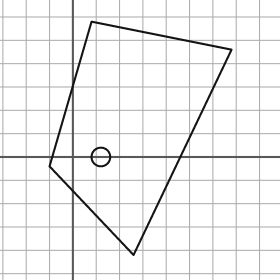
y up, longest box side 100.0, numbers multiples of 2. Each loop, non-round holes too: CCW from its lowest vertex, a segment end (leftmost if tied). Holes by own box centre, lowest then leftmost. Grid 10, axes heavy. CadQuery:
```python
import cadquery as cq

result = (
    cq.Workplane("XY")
    .moveTo(26.0, -42.0)
    .lineTo(68.0, 46.0)
    .lineTo(8.0, 58.0)
    .lineTo(-10.0, -4.0)
    .close()
    .moveTo(12.0, 0.0)
    .circle(4.0)
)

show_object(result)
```